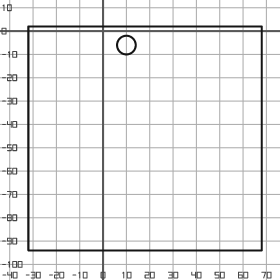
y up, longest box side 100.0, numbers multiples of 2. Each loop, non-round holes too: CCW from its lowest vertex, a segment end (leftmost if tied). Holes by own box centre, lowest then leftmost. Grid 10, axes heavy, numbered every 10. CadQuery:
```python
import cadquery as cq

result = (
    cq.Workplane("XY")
    .moveTo(-32.0, -94.0)
    .lineTo(68.0, -94.0)
    .lineTo(68.0, 2.0)
    .lineTo(-32.0, 2.0)
    .close()
    .moveTo(10.0, -6.0)
    .circle(4.0)
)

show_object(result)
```